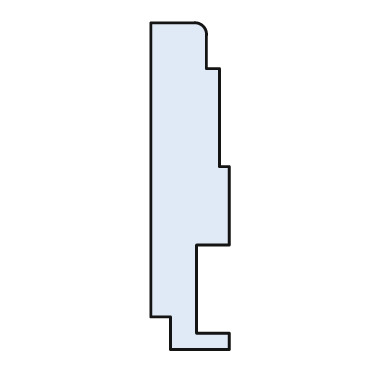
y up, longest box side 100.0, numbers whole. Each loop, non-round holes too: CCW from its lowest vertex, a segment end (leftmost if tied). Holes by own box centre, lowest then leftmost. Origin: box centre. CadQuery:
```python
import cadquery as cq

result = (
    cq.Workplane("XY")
    .moveTo(-6.0, -50.0)
    .lineTo(12.0, -50.0)
    .lineTo(12.0, -45.0)
    .lineTo(2.0, -45.0)
    .lineTo(2.0, -18.0)
    .lineTo(12.0, -18.0)
    .lineTo(12.0, 6.0)
    .lineTo(9.0, 6.0)
    .lineTo(9.0, 36.0)
    .lineTo(5.0, 36.0)
    .lineTo(5.0, 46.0)
    .threePointArc((4.0, 49.0), (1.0, 50.0))
    .lineTo(-12.0, 50.0)
    .lineTo(-12.0, -40.0)
    .lineTo(-6.0, -40.0)
    .close()
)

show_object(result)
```